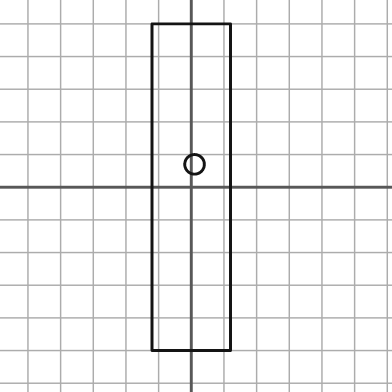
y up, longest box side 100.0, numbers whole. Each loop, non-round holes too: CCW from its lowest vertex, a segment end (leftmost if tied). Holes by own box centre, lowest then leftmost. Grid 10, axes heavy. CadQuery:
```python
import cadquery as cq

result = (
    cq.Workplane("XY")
    .moveTo(-12.0, -50.0)
    .lineTo(12.0, -50.0)
    .lineTo(12.0, 50.0)
    .lineTo(-12.0, 50.0)
    .close()
    .moveTo(1.0, 7.0)
    .circle(3.0)
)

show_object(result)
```